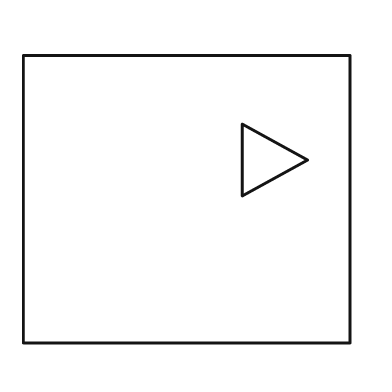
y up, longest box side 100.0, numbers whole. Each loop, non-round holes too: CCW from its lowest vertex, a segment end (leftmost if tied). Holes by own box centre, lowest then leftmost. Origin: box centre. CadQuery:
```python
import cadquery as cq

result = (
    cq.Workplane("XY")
    .moveTo(-50.0, -44.0)
    .lineTo(50.0, -44.0)
    .lineTo(50.0, 44.0)
    .lineTo(-50.0, 44.0)
    .close()
    .moveTo(17.0, 1.0)
    .lineTo(37.0, 12.0)
    .lineTo(17.0, 23.0)
    .close()
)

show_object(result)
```